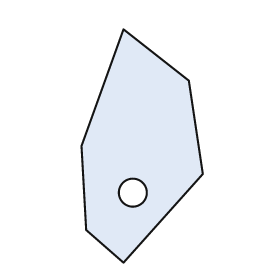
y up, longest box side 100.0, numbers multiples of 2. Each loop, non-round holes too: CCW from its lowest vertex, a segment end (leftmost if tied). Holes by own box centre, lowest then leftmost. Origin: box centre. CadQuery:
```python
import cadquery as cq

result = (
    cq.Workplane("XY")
    .moveTo(-8.0, -50.0)
    .lineTo(26.0, -12.0)
    .lineTo(20.0, 28.0)
    .lineTo(-8.0, 50.0)
    .lineTo(-26.0, 0.0)
    .lineTo(-24.0, -36.0)
    .close()
    .moveTo(-4.0, -20.0)
    .circle(6.0)
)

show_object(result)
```